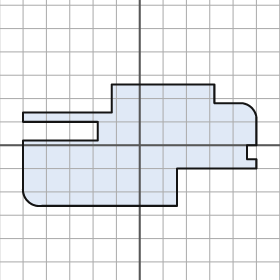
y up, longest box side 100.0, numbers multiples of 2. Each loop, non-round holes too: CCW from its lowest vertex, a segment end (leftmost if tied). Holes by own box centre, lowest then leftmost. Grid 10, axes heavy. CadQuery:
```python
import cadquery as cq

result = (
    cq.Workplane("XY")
    .moveTo(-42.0, -26.0)
    .lineTo(16.0, -26.0)
    .lineTo(16.0, -10.0)
    .lineTo(50.0, -10.0)
    .lineTo(50.0, -6.0)
    .lineTo(46.0, -6.0)
    .lineTo(46.0, 0.0)
    .lineTo(50.0, 0.0)
    .lineTo(50.0, 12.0)
    .threePointArc((48.0, 16.0), (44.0, 18.0))
    .lineTo(32.0, 18.0)
    .lineTo(32.0, 26.0)
    .lineTo(-12.0, 26.0)
    .lineTo(-12.0, 14.0)
    .lineTo(-50.0, 14.0)
    .lineTo(-50.0, 10.0)
    .lineTo(-18.0, 10.0)
    .lineTo(-18.0, 2.0)
    .lineTo(-50.0, 2.0)
    .lineTo(-50.0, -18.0)
    .threePointArc((-48.0, -24.0), (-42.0, -26.0))
    .close()
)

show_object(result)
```